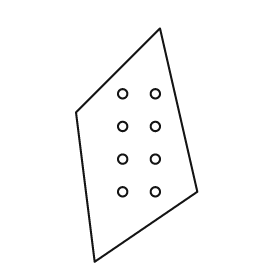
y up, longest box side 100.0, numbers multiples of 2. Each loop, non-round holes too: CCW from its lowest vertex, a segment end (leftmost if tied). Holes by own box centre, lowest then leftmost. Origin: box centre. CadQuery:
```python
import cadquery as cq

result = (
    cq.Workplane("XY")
    .moveTo(-18.0, -50.0)
    .lineTo(26.0, -20.0)
    .lineTo(10.0, 50.0)
    .lineTo(-26.0, 14.0)
    .close()
    .moveTo(-6.0, -20.0)
    .circle(2.0)
    .moveTo(8.0, -20.0)
    .circle(2.0)
    .moveTo(-6.0, -6.0)
    .circle(2.0)
    .moveTo(8.0, -6.0)
    .circle(2.0)
    .moveTo(-6.0, 8.0)
    .circle(2.0)
    .moveTo(8.0, 8.0)
    .circle(2.0)
    .moveTo(-6.0, 22.0)
    .circle(2.0)
    .moveTo(8.0, 22.0)
    .circle(2.0)
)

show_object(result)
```